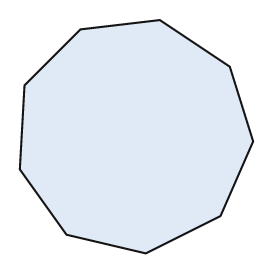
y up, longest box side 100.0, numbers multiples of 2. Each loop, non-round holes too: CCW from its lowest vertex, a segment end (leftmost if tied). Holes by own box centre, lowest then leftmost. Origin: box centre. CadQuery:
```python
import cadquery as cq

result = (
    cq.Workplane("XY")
    .moveTo(4.0, -50.0)
    .lineTo(36.0, -34.0)
    .lineTo(50.0, -2.0)
    .lineTo(40.0, 30.0)
    .lineTo(10.0, 50.0)
    .lineTo(-24.0, 46.0)
    .lineTo(-48.0, 22.0)
    .lineTo(-50.0, -14.0)
    .lineTo(-30.0, -42.0)
    .close()
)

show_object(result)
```